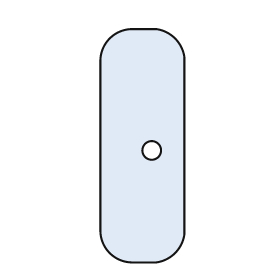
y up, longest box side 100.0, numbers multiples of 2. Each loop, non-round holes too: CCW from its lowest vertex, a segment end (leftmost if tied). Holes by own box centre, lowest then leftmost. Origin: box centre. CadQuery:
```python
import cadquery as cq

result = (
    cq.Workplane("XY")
    .moveTo(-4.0, -50.0)
    .lineTo(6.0, -50.0)
    .threePointArc((14.0, -46.0), (18.0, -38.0))
    .lineTo(18.0, 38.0)
    .threePointArc((14.0, 46.0), (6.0, 50.0))
    .lineTo(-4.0, 50.0)
    .threePointArc((-14.0, 46.0), (-18.0, 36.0))
    .lineTo(-18.0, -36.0)
    .threePointArc((-14.0, -46.0), (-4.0, -50.0))
    .close()
    .moveTo(4.0, -2.0)
    .circle(4.0)
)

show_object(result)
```